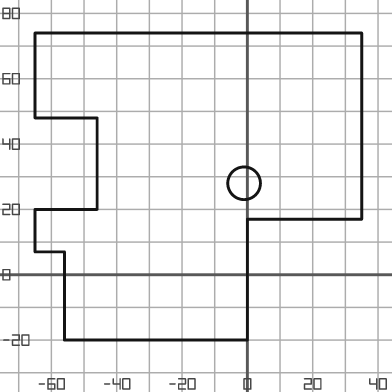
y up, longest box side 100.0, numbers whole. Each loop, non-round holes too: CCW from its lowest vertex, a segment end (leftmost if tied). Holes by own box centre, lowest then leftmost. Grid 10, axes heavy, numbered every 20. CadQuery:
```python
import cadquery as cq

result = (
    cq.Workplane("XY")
    .moveTo(-56.0, -20.0)
    .lineTo(0.0, -20.0)
    .lineTo(0.0, 17.0)
    .lineTo(35.0, 17.0)
    .lineTo(35.0, 74.0)
    .lineTo(-65.0, 74.0)
    .lineTo(-65.0, 48.0)
    .lineTo(-46.0, 48.0)
    .lineTo(-46.0, 20.0)
    .lineTo(-65.0, 20.0)
    .lineTo(-65.0, 7.0)
    .lineTo(-56.0, 7.0)
    .close()
    .moveTo(-1.0, 28.0)
    .circle(5.0)
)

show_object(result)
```